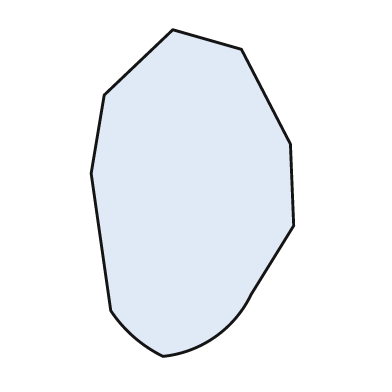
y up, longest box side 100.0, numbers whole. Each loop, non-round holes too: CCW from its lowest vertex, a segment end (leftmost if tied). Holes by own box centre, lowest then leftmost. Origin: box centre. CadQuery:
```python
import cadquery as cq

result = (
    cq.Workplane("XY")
    .moveTo(-9.0, -50.0)
    .threePointArc((7.0, -44.0), (18.0, -31.0))
    .lineTo(31.0, -10.0)
    .lineTo(30.0, 15.0)
    .lineTo(15.0, 44.0)
    .lineTo(-6.0, 50.0)
    .lineTo(-27.0, 30.0)
    .lineTo(-31.0, 6.0)
    .lineTo(-25.0, -36.0)
    .threePointArc((-18.0, -44.0), (-9.0, -50.0))
    .close()
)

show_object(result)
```